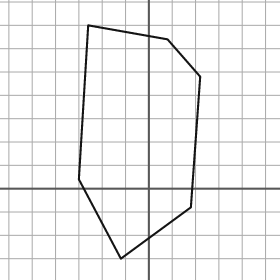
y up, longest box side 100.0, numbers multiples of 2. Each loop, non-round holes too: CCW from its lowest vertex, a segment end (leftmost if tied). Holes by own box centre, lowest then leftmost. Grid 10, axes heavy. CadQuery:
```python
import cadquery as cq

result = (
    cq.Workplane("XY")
    .moveTo(-12.0, -30.0)
    .lineTo(18.0, -8.0)
    .lineTo(22.0, 48.0)
    .lineTo(8.0, 64.0)
    .lineTo(-26.0, 70.0)
    .lineTo(-30.0, 4.0)
    .close()
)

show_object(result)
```